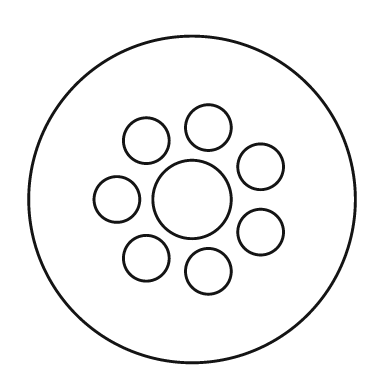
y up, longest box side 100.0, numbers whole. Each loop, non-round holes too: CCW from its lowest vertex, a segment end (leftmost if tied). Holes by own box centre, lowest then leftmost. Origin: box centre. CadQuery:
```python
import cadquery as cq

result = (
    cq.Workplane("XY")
    .moveTo(0.0, 0.0)
    .circle(50.0)
    .moveTo(5.0, -22.0)
    .circle(7.0)
    .moveTo(-14.0, -18.0)
    .circle(7.0)
    .moveTo(21.0, -10.0)
    .circle(7.0)
    .moveTo(-23.0, 0.0)
    .circle(7.0)
    .moveTo(0.0, 0.0)
    .circle(12.0)
    .moveTo(21.0, 10.0)
    .circle(7.0)
    .moveTo(-14.0, 18.0)
    .circle(7.0)
    .moveTo(5.0, 22.0)
    .circle(7.0)
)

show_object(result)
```